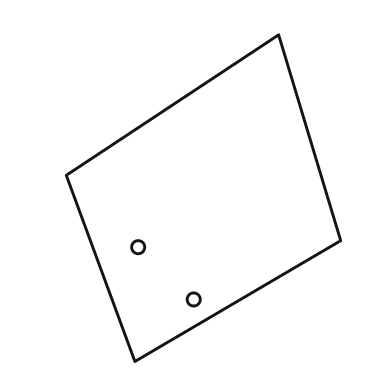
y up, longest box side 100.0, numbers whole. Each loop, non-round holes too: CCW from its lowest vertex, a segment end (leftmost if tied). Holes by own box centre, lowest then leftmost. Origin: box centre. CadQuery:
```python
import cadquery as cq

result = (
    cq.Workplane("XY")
    .moveTo(-21.0, -50.0)
    .lineTo(42.0, -13.0)
    .lineTo(23.0, 50.0)
    .lineTo(-42.0, 7.0)
    .close()
    .moveTo(-3.0, -31.0)
    .circle(2.0)
    .moveTo(-20.0, -15.0)
    .circle(2.0)
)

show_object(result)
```